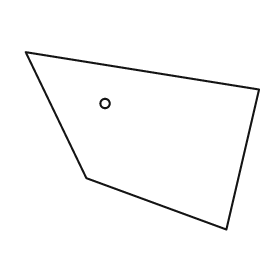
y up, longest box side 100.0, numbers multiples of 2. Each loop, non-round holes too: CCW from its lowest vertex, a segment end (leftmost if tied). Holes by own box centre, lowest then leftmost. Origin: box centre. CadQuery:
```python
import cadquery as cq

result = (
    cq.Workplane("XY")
    .moveTo(36.0, -38.0)
    .lineTo(50.0, 22.0)
    .lineTo(-50.0, 38.0)
    .lineTo(-24.0, -16.0)
    .close()
    .moveTo(-16.0, 16.0)
    .circle(2.0)
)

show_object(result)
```